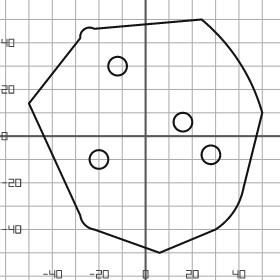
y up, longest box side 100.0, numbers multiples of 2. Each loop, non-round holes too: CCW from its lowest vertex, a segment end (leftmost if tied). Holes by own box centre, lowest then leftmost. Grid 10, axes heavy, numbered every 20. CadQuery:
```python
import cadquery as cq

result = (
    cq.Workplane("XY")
    .moveTo(6.0, -50.0)
    .lineTo(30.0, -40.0)
    .threePointArc((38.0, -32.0), (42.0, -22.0))
    .lineTo(50.0, 10.0)
    .threePointArc((40.0, 32.0), (24.0, 50.0))
    .lineTo(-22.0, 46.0)
    .threePointArc((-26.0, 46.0), (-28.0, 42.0))
    .lineTo(-50.0, 14.0)
    .lineTo(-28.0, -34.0)
    .threePointArc((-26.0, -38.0), (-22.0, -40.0))
    .close()
    .moveTo(-20.0, -10.0)
    .circle(4.0)
    .moveTo(28.0, -8.0)
    .circle(4.0)
    .moveTo(16.0, 6.0)
    .circle(4.0)
    .moveTo(-12.0, 30.0)
    .circle(4.0)
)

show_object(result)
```